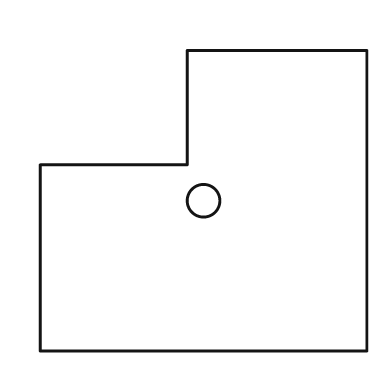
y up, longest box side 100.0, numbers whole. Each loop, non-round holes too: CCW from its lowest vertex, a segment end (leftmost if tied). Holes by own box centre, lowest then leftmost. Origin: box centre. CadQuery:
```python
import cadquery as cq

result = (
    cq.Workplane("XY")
    .moveTo(-50.0, -46.0)
    .lineTo(50.0, -46.0)
    .lineTo(50.0, 46.0)
    .lineTo(-5.0, 46.0)
    .lineTo(-5.0, 11.0)
    .lineTo(-50.0, 11.0)
    .close()
    .moveTo(0.0, 0.0)
    .circle(5.0)
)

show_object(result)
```